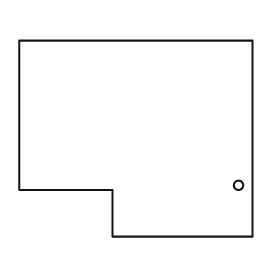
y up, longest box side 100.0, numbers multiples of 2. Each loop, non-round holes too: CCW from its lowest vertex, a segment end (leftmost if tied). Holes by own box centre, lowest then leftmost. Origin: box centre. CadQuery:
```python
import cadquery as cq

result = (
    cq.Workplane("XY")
    .moveTo(-10.0, -42.0)
    .lineTo(50.0, -42.0)
    .lineTo(50.0, 42.0)
    .lineTo(-50.0, 42.0)
    .lineTo(-50.0, -22.0)
    .lineTo(-10.0, -22.0)
    .close()
    .moveTo(44.0, -20.0)
    .circle(2.0)
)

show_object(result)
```